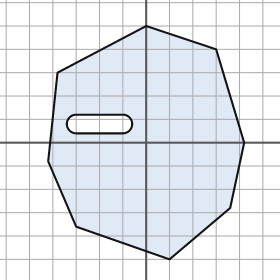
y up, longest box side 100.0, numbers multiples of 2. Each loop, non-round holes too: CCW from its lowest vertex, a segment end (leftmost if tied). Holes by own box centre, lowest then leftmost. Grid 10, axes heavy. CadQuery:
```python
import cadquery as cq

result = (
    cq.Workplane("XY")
    .moveTo(10.0, -50.0)
    .lineTo(36.0, -28.0)
    .lineTo(42.0, 0.0)
    .lineTo(30.0, 40.0)
    .lineTo(0.0, 50.0)
    .lineTo(-38.0, 30.0)
    .lineTo(-42.0, -8.0)
    .lineTo(-30.0, -36.0)
    .close()
    .moveTo(-30.0, 4.0)
    .lineTo(-10.0, 4.0)
    .threePointArc((-6.0, 8.0), (-10.0, 12.0))
    .lineTo(-30.0, 12.0)
    .threePointArc((-34.0, 8.0), (-30.0, 4.0))
    .close()
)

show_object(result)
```